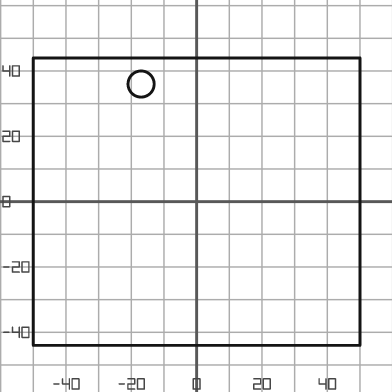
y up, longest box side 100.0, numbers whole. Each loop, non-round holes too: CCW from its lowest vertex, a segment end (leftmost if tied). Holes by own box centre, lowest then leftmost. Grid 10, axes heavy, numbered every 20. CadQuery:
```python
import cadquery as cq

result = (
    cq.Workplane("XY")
    .moveTo(-50.0, -44.0)
    .lineTo(50.0, -44.0)
    .lineTo(50.0, 44.0)
    .lineTo(-50.0, 44.0)
    .close()
    .moveTo(-17.0, 36.0)
    .circle(4.0)
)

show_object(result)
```